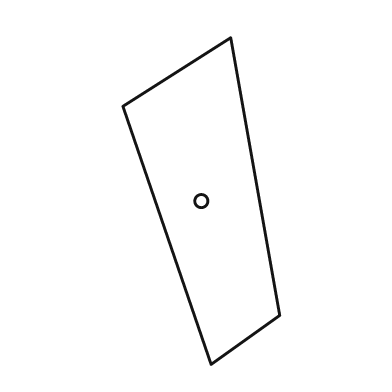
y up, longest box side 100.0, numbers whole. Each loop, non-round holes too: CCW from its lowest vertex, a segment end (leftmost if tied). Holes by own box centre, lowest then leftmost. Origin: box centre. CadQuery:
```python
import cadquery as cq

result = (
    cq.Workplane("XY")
    .moveTo(3.0, -50.0)
    .lineTo(24.0, -35.0)
    .lineTo(9.0, 50.0)
    .lineTo(-24.0, 29.0)
    .close()
    .moveTo(0.0, 0.0)
    .circle(2.0)
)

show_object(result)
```